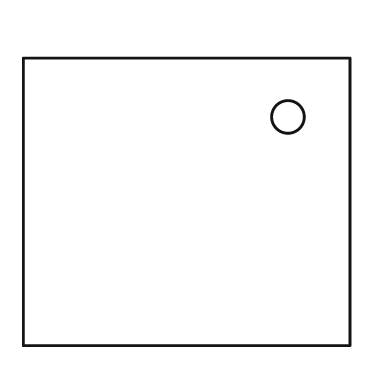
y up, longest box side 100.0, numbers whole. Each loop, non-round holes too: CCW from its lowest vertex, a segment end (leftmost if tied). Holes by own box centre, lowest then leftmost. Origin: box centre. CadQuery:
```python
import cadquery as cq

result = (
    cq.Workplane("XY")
    .moveTo(-50.0, -44.0)
    .lineTo(50.0, -44.0)
    .lineTo(50.0, 44.0)
    .lineTo(-50.0, 44.0)
    .close()
    .moveTo(31.0, 26.0)
    .circle(5.0)
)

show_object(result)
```